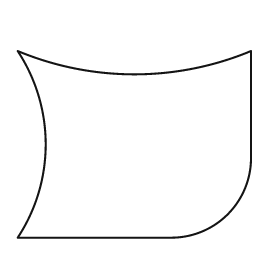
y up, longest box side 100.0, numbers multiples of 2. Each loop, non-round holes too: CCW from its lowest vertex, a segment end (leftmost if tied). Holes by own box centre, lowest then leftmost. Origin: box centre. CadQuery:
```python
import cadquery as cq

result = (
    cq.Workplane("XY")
    .moveTo(-50.0, -40.0)
    .lineTo(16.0, -40.0)
    .threePointArc((40.0, -30.0), (50.0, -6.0))
    .lineTo(50.0, 40.0)
    .threePointArc((0.0, 30.0), (-50.0, 40.0))
    .threePointArc((-38.0, 0.0), (-50.0, -40.0))
    .close()
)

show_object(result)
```